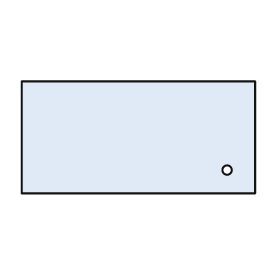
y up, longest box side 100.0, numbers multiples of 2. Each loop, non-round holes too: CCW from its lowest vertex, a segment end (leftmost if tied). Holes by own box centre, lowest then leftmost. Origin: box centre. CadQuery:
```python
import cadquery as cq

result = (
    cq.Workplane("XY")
    .moveTo(-50.0, -24.0)
    .lineTo(50.0, -24.0)
    .lineTo(50.0, 24.0)
    .lineTo(-50.0, 24.0)
    .close()
    .moveTo(38.0, -14.0)
    .circle(2.0)
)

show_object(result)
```